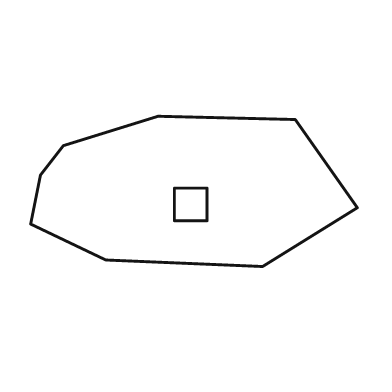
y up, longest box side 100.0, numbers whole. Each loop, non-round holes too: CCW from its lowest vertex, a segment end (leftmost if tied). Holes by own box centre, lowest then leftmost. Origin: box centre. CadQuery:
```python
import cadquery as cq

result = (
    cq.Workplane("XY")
    .moveTo(21.0, -23.0)
    .lineTo(50.0, -5.0)
    .lineTo(31.0, 22.0)
    .lineTo(-11.0, 23.0)
    .lineTo(-40.0, 14.0)
    .lineTo(-47.0, 5.0)
    .lineTo(-50.0, -10.0)
    .lineTo(-27.0, -21.0)
    .close()
    .moveTo(-6.0, -9.0)
    .lineTo(4.0, -9.0)
    .lineTo(4.0, 1.0)
    .lineTo(-6.0, 1.0)
    .close()
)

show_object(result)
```